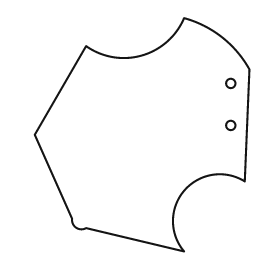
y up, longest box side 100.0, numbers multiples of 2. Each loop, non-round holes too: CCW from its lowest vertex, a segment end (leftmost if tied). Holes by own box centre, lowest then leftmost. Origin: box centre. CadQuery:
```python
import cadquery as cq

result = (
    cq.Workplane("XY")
    .moveTo(18.0, -50.0)
    .threePointArc((18.0, -24.0), (44.0, -20.0))
    .lineTo(46.0, 28.0)
    .threePointArc((34.0, 42.0), (18.0, 50.0))
    .threePointArc((0.0, 34.0), (-24.0, 38.0))
    .lineTo(-46.0, 0.0)
    .lineTo(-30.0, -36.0)
    .threePointArc((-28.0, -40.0), (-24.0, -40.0))
    .close()
    .moveTo(38.0, 4.0)
    .circle(2.0)
    .moveTo(38.0, 22.0)
    .circle(2.0)
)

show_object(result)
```